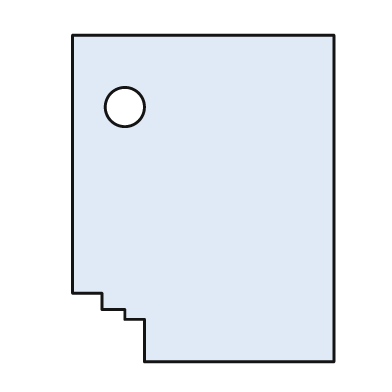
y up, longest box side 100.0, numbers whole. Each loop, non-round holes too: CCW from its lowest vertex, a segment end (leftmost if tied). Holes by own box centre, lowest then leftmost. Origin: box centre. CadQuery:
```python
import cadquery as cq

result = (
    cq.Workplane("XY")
    .moveTo(-18.0, -50.0)
    .lineTo(40.0, -50.0)
    .lineTo(40.0, 50.0)
    .lineTo(-40.0, 50.0)
    .lineTo(-40.0, -29.0)
    .lineTo(-31.0, -29.0)
    .lineTo(-31.0, -34.0)
    .lineTo(-24.0, -34.0)
    .lineTo(-24.0, -37.0)
    .lineTo(-18.0, -37.0)
    .close()
    .moveTo(-24.0, 28.0)
    .circle(6.0)
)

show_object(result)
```